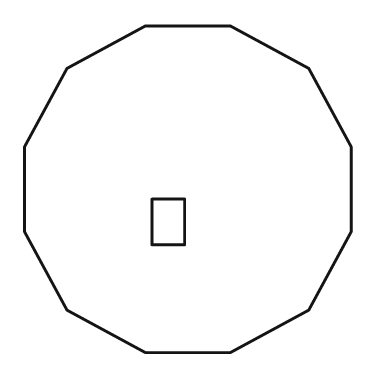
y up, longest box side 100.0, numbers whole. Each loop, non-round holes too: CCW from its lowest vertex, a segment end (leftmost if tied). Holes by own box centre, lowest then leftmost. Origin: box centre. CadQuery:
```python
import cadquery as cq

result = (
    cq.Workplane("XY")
    .moveTo(-13.0, -50.0)
    .lineTo(13.0, -50.0)
    .lineTo(37.0, -37.0)
    .lineTo(50.0, -13.0)
    .lineTo(50.0, 13.0)
    .lineTo(37.0, 37.0)
    .lineTo(13.0, 50.0)
    .lineTo(-13.0, 50.0)
    .lineTo(-37.0, 37.0)
    .lineTo(-50.0, 13.0)
    .lineTo(-50.0, -13.0)
    .lineTo(-37.0, -37.0)
    .close()
    .moveTo(-11.0, -17.0)
    .lineTo(-1.0, -17.0)
    .lineTo(-1.0, -3.0)
    .lineTo(-11.0, -3.0)
    .close()
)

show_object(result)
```